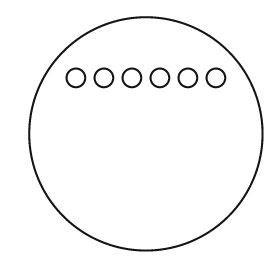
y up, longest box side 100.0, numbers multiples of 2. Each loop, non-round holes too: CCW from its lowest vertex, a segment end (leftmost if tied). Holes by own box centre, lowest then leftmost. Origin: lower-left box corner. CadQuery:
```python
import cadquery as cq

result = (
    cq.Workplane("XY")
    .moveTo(50.0, 50.0)
    .circle(50.0)
    .moveTo(20.0, 74.0)
    .circle(4.0)
    .moveTo(32.0, 74.0)
    .circle(4.0)
    .moveTo(44.0, 74.0)
    .circle(4.0)
    .moveTo(56.0, 74.0)
    .circle(4.0)
    .moveTo(68.0, 74.0)
    .circle(4.0)
    .moveTo(80.0, 74.0)
    .circle(4.0)
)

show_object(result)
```